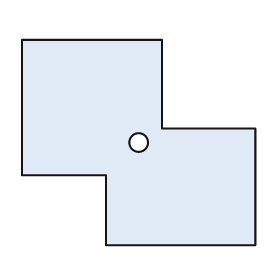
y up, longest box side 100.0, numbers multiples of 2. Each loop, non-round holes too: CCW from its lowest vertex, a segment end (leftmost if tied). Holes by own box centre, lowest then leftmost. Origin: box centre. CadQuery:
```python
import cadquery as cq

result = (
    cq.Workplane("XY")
    .moveTo(-14.0, -44.0)
    .lineTo(50.0, -44.0)
    .lineTo(50.0, 6.0)
    .lineTo(10.0, 6.0)
    .lineTo(10.0, 44.0)
    .lineTo(-50.0, 44.0)
    .lineTo(-50.0, -14.0)
    .lineTo(-14.0, -14.0)
    .close()
    .moveTo(0.0, 0.0)
    .circle(4.0)
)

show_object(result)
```